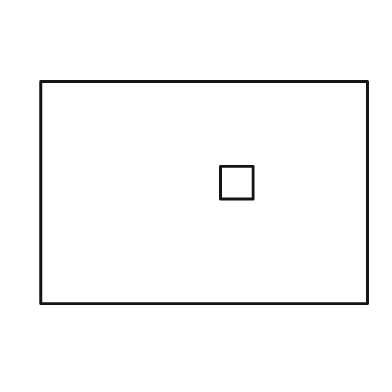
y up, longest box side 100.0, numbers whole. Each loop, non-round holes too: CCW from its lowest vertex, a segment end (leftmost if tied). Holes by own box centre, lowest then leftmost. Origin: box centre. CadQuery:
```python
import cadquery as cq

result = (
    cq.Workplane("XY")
    .moveTo(-50.0, -34.0)
    .lineTo(50.0, -34.0)
    .lineTo(50.0, 34.0)
    .lineTo(-50.0, 34.0)
    .close()
    .moveTo(5.0, -2.0)
    .lineTo(15.0, -2.0)
    .lineTo(15.0, 8.0)
    .lineTo(5.0, 8.0)
    .close()
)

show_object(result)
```